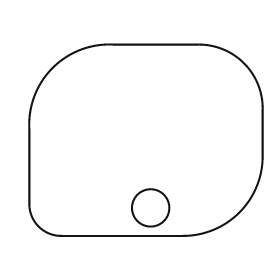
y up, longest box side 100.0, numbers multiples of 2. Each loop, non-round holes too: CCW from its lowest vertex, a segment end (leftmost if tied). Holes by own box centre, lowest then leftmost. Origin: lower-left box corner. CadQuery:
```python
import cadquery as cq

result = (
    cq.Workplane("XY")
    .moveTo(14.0, 0.0)
    .lineTo(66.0, 0.0)
    .threePointArc((90.0, 10.0), (100.0, 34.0))
    .lineTo(100.0, 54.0)
    .threePointArc((92.0, 74.0), (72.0, 82.0))
    .lineTo(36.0, 82.0)
    .threePointArc((10.0, 72.0), (0.0, 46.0))
    .lineTo(0.0, 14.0)
    .threePointArc((4.0, 4.0), (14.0, 0.0))
    .close()
    .moveTo(52.0, 12.0)
    .circle(8.0)
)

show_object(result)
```